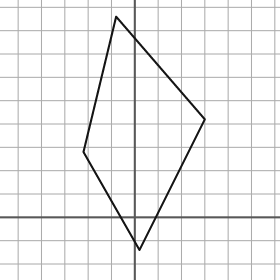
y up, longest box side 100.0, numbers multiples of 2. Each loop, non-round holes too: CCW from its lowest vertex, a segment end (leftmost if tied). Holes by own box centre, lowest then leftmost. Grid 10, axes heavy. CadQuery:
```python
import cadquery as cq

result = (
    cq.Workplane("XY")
    .moveTo(2.0, -14.0)
    .lineTo(30.0, 42.0)
    .lineTo(-8.0, 86.0)
    .lineTo(-22.0, 28.0)
    .close()
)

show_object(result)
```